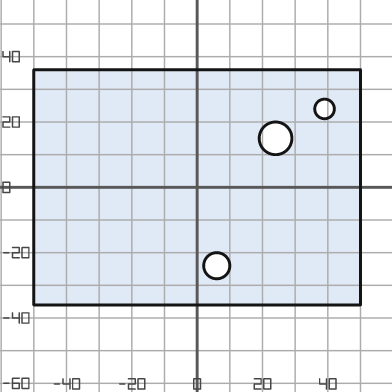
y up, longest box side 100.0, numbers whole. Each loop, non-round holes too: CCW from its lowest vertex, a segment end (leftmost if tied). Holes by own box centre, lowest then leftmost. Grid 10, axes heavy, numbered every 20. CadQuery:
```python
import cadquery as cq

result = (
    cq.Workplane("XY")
    .moveTo(-50.0, -36.0)
    .lineTo(50.0, -36.0)
    .lineTo(50.0, 36.0)
    .lineTo(-50.0, 36.0)
    .close()
    .moveTo(6.0, -24.0)
    .circle(4.0)
    .moveTo(24.0, 15.0)
    .circle(5.0)
    .moveTo(39.0, 24.0)
    .circle(3.0)
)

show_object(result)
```